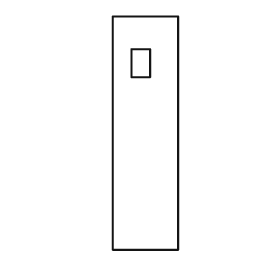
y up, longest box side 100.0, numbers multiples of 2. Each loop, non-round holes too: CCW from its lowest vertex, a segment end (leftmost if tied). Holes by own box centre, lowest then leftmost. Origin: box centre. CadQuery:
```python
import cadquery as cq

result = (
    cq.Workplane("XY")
    .moveTo(-14.0, -50.0)
    .lineTo(14.0, -50.0)
    .lineTo(14.0, 50.0)
    .lineTo(-14.0, 50.0)
    .close()
    .moveTo(-6.0, 24.0)
    .lineTo(2.0, 24.0)
    .lineTo(2.0, 36.0)
    .lineTo(-6.0, 36.0)
    .close()
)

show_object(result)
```